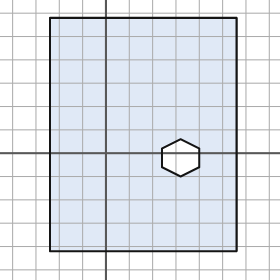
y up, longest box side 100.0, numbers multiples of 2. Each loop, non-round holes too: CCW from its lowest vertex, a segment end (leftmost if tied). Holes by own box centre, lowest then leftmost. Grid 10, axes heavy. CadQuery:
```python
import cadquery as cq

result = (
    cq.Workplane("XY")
    .moveTo(-24.0, -42.0)
    .lineTo(56.0, -42.0)
    .lineTo(56.0, 58.0)
    .lineTo(-24.0, 58.0)
    .close()
    .moveTo(32.0, -10.0)
    .lineTo(40.0, -6.0)
    .lineTo(40.0, 2.0)
    .lineTo(32.0, 6.0)
    .lineTo(24.0, 2.0)
    .lineTo(24.0, -6.0)
    .close()
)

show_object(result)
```